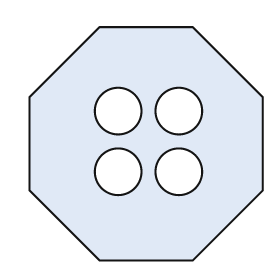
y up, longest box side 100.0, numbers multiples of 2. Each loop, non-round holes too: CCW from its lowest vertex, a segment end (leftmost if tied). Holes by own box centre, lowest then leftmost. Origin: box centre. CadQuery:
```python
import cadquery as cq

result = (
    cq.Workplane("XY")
    .moveTo(-20.0, -50.0)
    .lineTo(20.0, -50.0)
    .lineTo(50.0, -20.0)
    .lineTo(50.0, 20.0)
    .lineTo(20.0, 50.0)
    .lineTo(-20.0, 50.0)
    .lineTo(-50.0, 20.0)
    .lineTo(-50.0, -20.0)
    .close()
    .moveTo(-12.0, -12.0)
    .circle(10.0)
    .moveTo(14.0, -12.0)
    .circle(10.0)
    .moveTo(-12.0, 14.0)
    .circle(10.0)
    .moveTo(14.0, 14.0)
    .circle(10.0)
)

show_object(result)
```